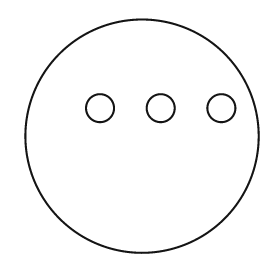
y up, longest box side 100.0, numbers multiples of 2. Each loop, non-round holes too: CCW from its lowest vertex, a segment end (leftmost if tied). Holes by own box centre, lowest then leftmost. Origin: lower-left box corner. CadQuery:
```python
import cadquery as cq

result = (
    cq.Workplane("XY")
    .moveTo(50.0, 50.0)
    .circle(50.0)
    .moveTo(32.0, 62.0)
    .circle(6.0)
    .moveTo(58.0, 62.0)
    .circle(6.0)
    .moveTo(84.0, 62.0)
    .circle(6.0)
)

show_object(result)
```